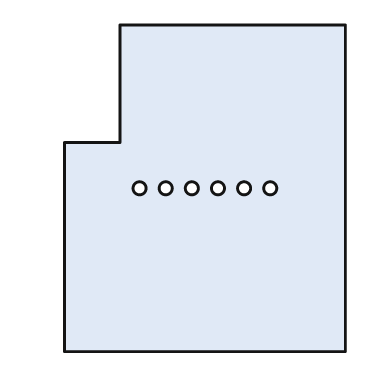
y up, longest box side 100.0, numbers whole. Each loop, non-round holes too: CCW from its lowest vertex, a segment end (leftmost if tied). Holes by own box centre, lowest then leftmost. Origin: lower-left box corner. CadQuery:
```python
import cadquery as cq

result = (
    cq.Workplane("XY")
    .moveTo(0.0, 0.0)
    .lineTo(86.0, 0.0)
    .lineTo(86.0, 100.0)
    .lineTo(17.0, 100.0)
    .lineTo(17.0, 64.0)
    .lineTo(0.0, 64.0)
    .close()
    .moveTo(23.0, 50.0)
    .circle(2.0)
    .moveTo(31.0, 50.0)
    .circle(2.0)
    .moveTo(39.0, 50.0)
    .circle(2.0)
    .moveTo(47.0, 50.0)
    .circle(2.0)
    .moveTo(55.0, 50.0)
    .circle(2.0)
    .moveTo(63.0, 50.0)
    .circle(2.0)
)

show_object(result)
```